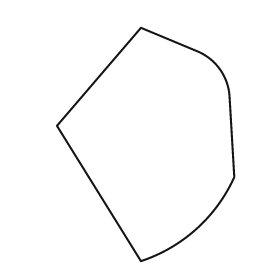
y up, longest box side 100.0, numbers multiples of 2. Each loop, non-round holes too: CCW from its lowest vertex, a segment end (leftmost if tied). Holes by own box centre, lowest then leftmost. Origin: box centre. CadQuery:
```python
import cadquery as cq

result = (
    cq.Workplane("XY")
    .moveTo(-2.0, -50.0)
    .threePointArc((22.0, -36.0), (38.0, -14.0))
    .lineTo(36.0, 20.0)
    .threePointArc((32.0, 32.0), (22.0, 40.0))
    .lineTo(-2.0, 50.0)
    .lineTo(-38.0, 8.0)
    .close()
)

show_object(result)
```